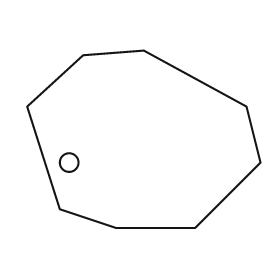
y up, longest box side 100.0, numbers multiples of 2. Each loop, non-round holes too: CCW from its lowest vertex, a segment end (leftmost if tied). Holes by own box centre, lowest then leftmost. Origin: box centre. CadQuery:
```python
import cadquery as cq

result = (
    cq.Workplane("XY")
    .moveTo(-12.0, -38.0)
    .lineTo(22.0, -38.0)
    .lineTo(50.0, -10.0)
    .lineTo(44.0, 14.0)
    .lineTo(0.0, 38.0)
    .lineTo(-26.0, 36.0)
    .lineTo(-50.0, 14.0)
    .lineTo(-36.0, -30.0)
    .close()
    .moveTo(-32.0, -10.0)
    .circle(4.0)
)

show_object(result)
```